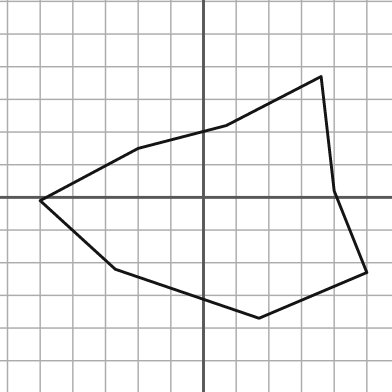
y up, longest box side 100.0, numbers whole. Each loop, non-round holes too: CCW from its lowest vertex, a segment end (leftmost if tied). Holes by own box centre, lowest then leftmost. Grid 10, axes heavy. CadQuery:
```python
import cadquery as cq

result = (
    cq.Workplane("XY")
    .moveTo(17.0, -37.0)
    .lineTo(50.0, -23.0)
    .lineTo(40.0, 2.0)
    .lineTo(36.0, 37.0)
    .lineTo(7.0, 22.0)
    .lineTo(-20.0, 15.0)
    .lineTo(-50.0, -1.0)
    .lineTo(-27.0, -22.0)
    .close()
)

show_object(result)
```